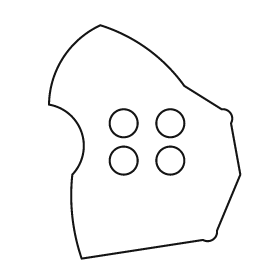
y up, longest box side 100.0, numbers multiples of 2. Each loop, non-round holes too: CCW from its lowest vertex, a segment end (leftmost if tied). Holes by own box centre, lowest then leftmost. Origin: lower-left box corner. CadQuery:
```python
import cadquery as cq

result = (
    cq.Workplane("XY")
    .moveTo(14.0, 0.0)
    .lineTo(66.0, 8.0)
    .threePointArc((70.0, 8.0), (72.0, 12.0))
    .lineTo(82.0, 36.0)
    .lineTo(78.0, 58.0)
    .threePointArc((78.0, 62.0), (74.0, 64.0))
    .lineTo(58.0, 74.0)
    .threePointArc((42.0, 90.0), (22.0, 100.0))
    .threePointArc((6.0, 86.0), (0.0, 66.0))
    .threePointArc((14.0, 54.0), (10.0, 36.0))
    .threePointArc((10.0, 18.0), (14.0, 0.0))
    .close()
    .moveTo(32.0, 42.0)
    .circle(6.0)
    .moveTo(52.0, 42.0)
    .circle(6.0)
    .moveTo(32.0, 58.0)
    .circle(6.0)
    .moveTo(52.0, 58.0)
    .circle(6.0)
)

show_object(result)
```